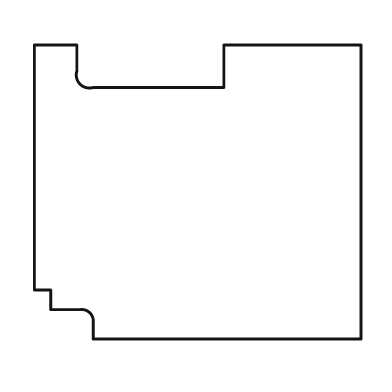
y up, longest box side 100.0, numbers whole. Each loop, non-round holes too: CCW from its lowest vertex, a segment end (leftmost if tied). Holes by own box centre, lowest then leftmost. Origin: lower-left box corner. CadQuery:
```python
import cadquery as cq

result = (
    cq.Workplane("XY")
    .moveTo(18.0, 0.0)
    .lineTo(100.0, 0.0)
    .lineTo(100.0, 90.0)
    .lineTo(58.0, 90.0)
    .lineTo(58.0, 77.0)
    .lineTo(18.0, 77.0)
    .threePointArc((14.0, 78.0), (13.0, 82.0))
    .lineTo(13.0, 90.0)
    .lineTo(0.0, 90.0)
    .lineTo(0.0, 15.0)
    .lineTo(5.0, 15.0)
    .lineTo(5.0, 9.0)
    .lineTo(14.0, 9.0)
    .threePointArc((17.0, 8.0), (18.0, 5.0))
    .close()
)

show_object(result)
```